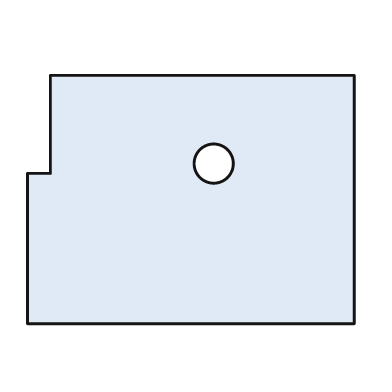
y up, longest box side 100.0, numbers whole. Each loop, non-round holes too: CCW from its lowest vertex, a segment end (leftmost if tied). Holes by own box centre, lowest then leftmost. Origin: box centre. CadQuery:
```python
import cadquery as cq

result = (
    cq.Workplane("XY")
    .moveTo(-50.0, -38.0)
    .lineTo(50.0, -38.0)
    .lineTo(50.0, 38.0)
    .lineTo(-43.0, 38.0)
    .lineTo(-43.0, 8.0)
    .lineTo(-50.0, 8.0)
    .close()
    .moveTo(7.0, 11.0)
    .circle(6.0)
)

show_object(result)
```